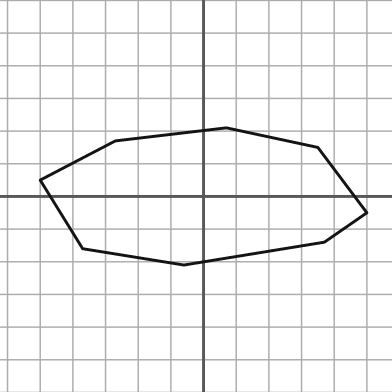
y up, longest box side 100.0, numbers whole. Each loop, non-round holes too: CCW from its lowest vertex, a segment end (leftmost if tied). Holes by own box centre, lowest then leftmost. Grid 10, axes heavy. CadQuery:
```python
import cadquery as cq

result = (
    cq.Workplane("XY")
    .moveTo(-6.0, -21.0)
    .lineTo(37.0, -14.0)
    .lineTo(50.0, -5.0)
    .lineTo(35.0, 15.0)
    .lineTo(7.0, 21.0)
    .lineTo(-27.0, 17.0)
    .lineTo(-50.0, 5.0)
    .lineTo(-37.0, -16.0)
    .close()
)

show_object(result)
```